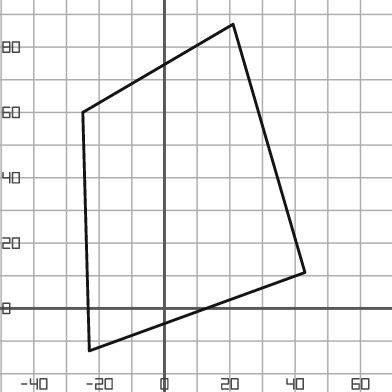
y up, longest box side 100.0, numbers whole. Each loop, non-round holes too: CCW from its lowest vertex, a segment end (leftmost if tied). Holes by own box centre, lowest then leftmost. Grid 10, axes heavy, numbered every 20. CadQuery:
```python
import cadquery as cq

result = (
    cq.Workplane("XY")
    .moveTo(-23.0, -13.0)
    .lineTo(43.0, 11.0)
    .lineTo(21.0, 87.0)
    .lineTo(-25.0, 60.0)
    .close()
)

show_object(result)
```